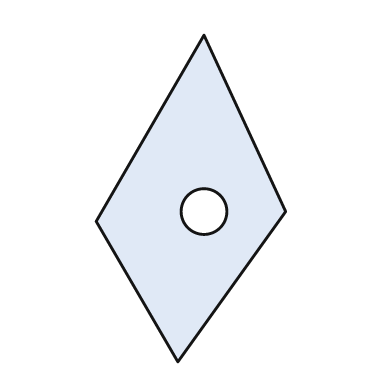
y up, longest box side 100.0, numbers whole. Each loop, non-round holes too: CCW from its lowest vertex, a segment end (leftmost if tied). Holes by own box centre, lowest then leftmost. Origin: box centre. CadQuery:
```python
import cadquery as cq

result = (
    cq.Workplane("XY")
    .moveTo(-4.0, -50.0)
    .lineTo(29.0, -4.0)
    .lineTo(4.0, 50.0)
    .lineTo(-29.0, -7.0)
    .close()
    .moveTo(4.0, -4.0)
    .circle(7.0)
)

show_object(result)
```